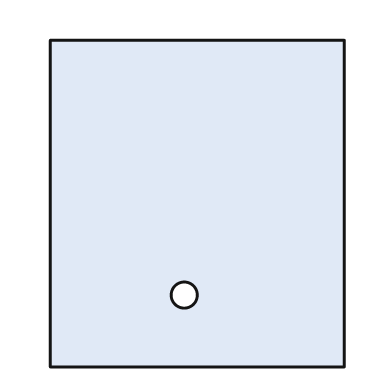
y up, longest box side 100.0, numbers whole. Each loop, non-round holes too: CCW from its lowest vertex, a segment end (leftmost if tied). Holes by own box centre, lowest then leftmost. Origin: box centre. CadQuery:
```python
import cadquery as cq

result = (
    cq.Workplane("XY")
    .moveTo(-45.0, -50.0)
    .lineTo(45.0, -50.0)
    .lineTo(45.0, 50.0)
    .lineTo(-45.0, 50.0)
    .close()
    .moveTo(-4.0, -28.0)
    .circle(4.0)
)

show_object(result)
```